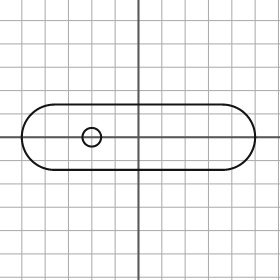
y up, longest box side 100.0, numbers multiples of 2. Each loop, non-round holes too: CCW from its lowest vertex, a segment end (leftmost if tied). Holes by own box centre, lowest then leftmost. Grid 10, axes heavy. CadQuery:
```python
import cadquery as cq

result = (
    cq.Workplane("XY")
    .moveTo(-36.0, -14.0)
    .lineTo(36.0, -14.0)
    .threePointArc((50.0, 0.0), (36.0, 14.0))
    .lineTo(-36.0, 14.0)
    .threePointArc((-50.0, 0.0), (-36.0, -14.0))
    .close()
    .moveTo(-20.0, 0.0)
    .circle(4.0)
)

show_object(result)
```